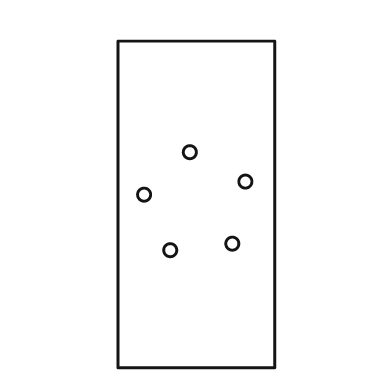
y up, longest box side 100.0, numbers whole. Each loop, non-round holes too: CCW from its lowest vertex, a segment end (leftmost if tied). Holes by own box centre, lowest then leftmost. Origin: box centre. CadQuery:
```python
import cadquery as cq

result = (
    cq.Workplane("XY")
    .moveTo(-24.0, -50.0)
    .lineTo(24.0, -50.0)
    .lineTo(24.0, 50.0)
    .lineTo(-24.0, 50.0)
    .close()
    .moveTo(-8.0, -14.0)
    .circle(2.0)
    .moveTo(11.0, -12.0)
    .circle(2.0)
    .moveTo(-16.0, 3.0)
    .circle(2.0)
    .moveTo(15.0, 7.0)
    .circle(2.0)
    .moveTo(-2.0, 16.0)
    .circle(2.0)
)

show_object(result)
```